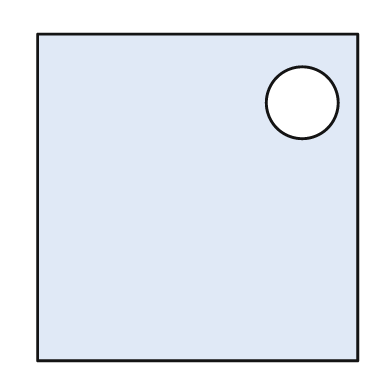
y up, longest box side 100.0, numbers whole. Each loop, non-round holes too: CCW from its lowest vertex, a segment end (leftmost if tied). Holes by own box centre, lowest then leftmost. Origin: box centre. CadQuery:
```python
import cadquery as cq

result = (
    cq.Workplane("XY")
    .moveTo(-49.0, -50.0)
    .lineTo(49.0, -50.0)
    .lineTo(49.0, 50.0)
    .lineTo(-49.0, 50.0)
    .close()
    .moveTo(32.0, 29.0)
    .circle(11.0)
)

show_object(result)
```